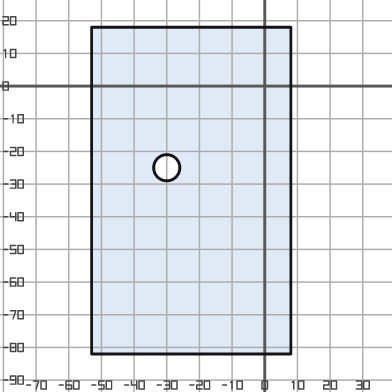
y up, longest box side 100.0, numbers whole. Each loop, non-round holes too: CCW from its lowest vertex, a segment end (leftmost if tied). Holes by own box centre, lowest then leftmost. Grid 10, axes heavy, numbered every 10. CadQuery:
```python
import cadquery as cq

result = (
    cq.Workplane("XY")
    .moveTo(-53.0, -82.0)
    .lineTo(8.0, -82.0)
    .lineTo(8.0, 18.0)
    .lineTo(-53.0, 18.0)
    .close()
    .moveTo(-30.0, -25.0)
    .circle(4.0)
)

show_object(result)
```